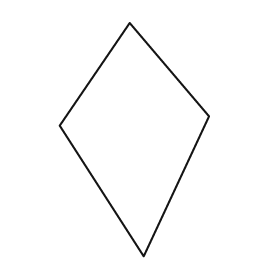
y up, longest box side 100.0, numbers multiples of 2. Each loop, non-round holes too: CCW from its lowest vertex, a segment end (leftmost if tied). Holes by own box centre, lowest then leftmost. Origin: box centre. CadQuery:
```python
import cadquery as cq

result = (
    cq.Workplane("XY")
    .moveTo(4.0, -50.0)
    .lineTo(32.0, 10.0)
    .lineTo(-2.0, 50.0)
    .lineTo(-32.0, 6.0)
    .close()
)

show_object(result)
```